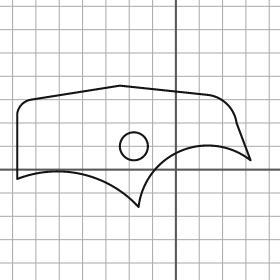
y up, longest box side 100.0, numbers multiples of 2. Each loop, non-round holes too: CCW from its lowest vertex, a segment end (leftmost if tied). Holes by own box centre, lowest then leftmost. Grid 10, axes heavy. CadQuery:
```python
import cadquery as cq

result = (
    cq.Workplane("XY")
    .moveTo(-16.0, -16.0)
    .threePointArc((2.0, 8.0), (32.0, 4.0))
    .lineTo(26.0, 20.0)
    .threePointArc((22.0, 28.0), (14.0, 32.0))
    .lineTo(-24.0, 36.0)
    .lineTo(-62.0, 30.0)
    .threePointArc((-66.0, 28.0), (-68.0, 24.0))
    .lineTo(-68.0, -4.0)
    .threePointArc((-40.0, -2.0), (-16.0, -16.0))
    .close()
    .moveTo(-18.0, 10.0)
    .circle(6.0)
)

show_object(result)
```